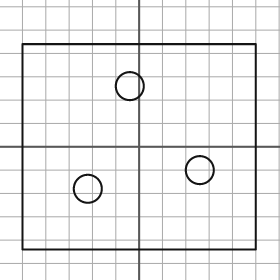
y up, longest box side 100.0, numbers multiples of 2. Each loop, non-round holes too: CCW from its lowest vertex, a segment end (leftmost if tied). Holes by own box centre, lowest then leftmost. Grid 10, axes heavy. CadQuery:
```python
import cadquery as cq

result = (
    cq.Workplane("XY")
    .moveTo(-50.0, -44.0)
    .lineTo(50.0, -44.0)
    .lineTo(50.0, 44.0)
    .lineTo(-50.0, 44.0)
    .close()
    .moveTo(-22.0, -18.0)
    .circle(6.0)
    .moveTo(26.0, -10.0)
    .circle(6.0)
    .moveTo(-4.0, 26.0)
    .circle(6.0)
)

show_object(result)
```